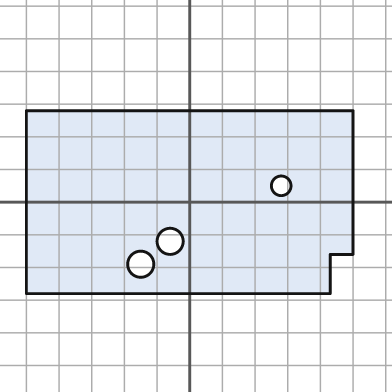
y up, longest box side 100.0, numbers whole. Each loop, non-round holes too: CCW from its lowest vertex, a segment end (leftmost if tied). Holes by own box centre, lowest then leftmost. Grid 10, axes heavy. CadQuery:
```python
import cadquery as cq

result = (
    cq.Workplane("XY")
    .moveTo(-50.0, -28.0)
    .lineTo(43.0, -28.0)
    .lineTo(43.0, -16.0)
    .lineTo(50.0, -16.0)
    .lineTo(50.0, 28.0)
    .lineTo(-50.0, 28.0)
    .close()
    .moveTo(-15.0, -19.0)
    .circle(4.0)
    .moveTo(-6.0, -12.0)
    .circle(4.0)
    .moveTo(28.0, 5.0)
    .circle(3.0)
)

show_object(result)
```